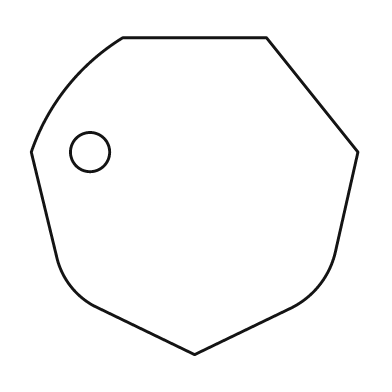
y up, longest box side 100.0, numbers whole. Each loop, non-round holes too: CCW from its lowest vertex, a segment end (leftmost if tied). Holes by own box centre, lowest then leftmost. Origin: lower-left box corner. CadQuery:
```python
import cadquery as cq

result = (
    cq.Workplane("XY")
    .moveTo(50.0, 0.0)
    .lineTo(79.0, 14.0)
    .threePointArc((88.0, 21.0), (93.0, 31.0))
    .lineTo(100.0, 62.0)
    .lineTo(72.0, 97.0)
    .lineTo(28.0, 97.0)
    .threePointArc((11.0, 82.0), (0.0, 62.0))
    .lineTo(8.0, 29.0)
    .threePointArc((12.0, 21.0), (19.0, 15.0))
    .close()
    .moveTo(18.0, 62.0)
    .circle(6.0)
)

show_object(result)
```